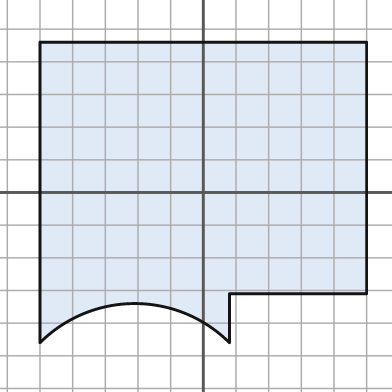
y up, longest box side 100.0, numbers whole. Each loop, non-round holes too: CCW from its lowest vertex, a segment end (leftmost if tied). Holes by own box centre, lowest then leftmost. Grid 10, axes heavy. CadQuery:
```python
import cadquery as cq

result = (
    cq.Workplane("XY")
    .moveTo(-50.0, -46.0)
    .threePointArc((-21.0, -34.0), (8.0, -46.0))
    .lineTo(8.0, -31.0)
    .lineTo(50.0, -31.0)
    .lineTo(50.0, 46.0)
    .lineTo(-50.0, 46.0)
    .close()
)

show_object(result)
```